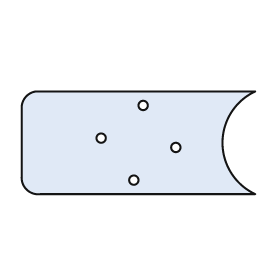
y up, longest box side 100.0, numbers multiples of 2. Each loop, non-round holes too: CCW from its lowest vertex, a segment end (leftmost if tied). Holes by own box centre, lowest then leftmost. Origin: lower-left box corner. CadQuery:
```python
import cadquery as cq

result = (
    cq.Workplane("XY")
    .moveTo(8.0, 0.0)
    .lineTo(100.0, 0.0)
    .threePointArc((86.0, 22.0), (100.0, 44.0))
    .lineTo(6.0, 44.0)
    .threePointArc((2.0, 42.0), (0.0, 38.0))
    .lineTo(0.0, 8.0)
    .threePointArc((2.0, 2.0), (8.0, 0.0))
    .close()
    .moveTo(48.0, 6.0)
    .circle(2.0)
    .moveTo(66.0, 20.0)
    .circle(2.0)
    .moveTo(34.0, 24.0)
    .circle(2.0)
    .moveTo(52.0, 38.0)
    .circle(2.0)
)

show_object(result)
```